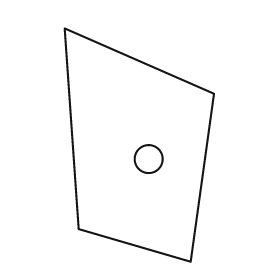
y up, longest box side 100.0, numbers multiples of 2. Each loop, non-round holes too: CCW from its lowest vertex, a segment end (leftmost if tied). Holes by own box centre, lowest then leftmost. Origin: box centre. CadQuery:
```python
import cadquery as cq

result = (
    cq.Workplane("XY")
    .moveTo(22.0, -50.0)
    .lineTo(32.0, 22.0)
    .lineTo(-32.0, 50.0)
    .lineTo(-26.0, -36.0)
    .close()
    .moveTo(4.0, -6.0)
    .circle(6.0)
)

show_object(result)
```